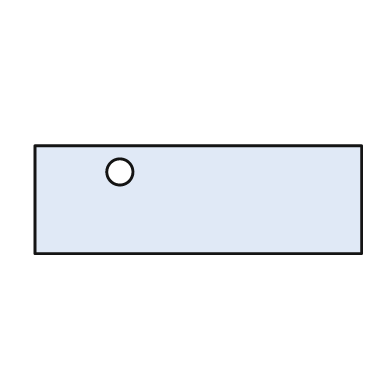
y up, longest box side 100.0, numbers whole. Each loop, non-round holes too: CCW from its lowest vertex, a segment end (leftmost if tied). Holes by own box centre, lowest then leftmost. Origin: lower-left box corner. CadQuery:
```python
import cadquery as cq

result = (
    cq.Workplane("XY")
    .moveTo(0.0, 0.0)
    .lineTo(100.0, 0.0)
    .lineTo(100.0, 33.0)
    .lineTo(0.0, 33.0)
    .close()
    .moveTo(26.0, 25.0)
    .circle(4.0)
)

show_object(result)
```